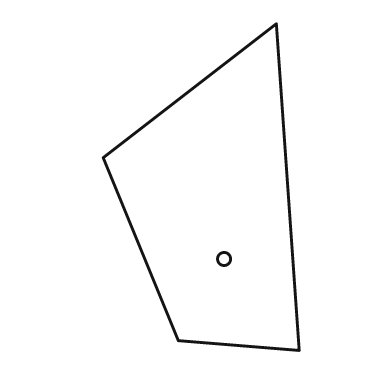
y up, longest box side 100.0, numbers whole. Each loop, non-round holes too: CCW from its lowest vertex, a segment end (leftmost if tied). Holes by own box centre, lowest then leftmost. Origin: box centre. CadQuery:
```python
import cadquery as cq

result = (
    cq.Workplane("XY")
    .moveTo(30.0, -50.0)
    .lineTo(23.0, 50.0)
    .lineTo(-30.0, 9.0)
    .lineTo(-7.0, -47.0)
    .close()
    .moveTo(7.0, -22.0)
    .circle(2.0)
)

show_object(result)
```